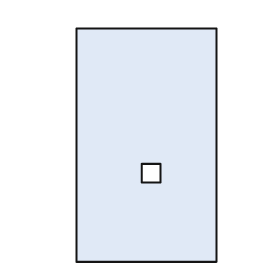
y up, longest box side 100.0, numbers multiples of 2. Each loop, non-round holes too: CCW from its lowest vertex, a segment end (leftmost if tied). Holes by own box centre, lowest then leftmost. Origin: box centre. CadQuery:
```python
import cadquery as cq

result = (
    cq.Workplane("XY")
    .moveTo(-30.0, -50.0)
    .lineTo(30.0, -50.0)
    .lineTo(30.0, 50.0)
    .lineTo(-30.0, 50.0)
    .close()
    .moveTo(-2.0, -16.0)
    .lineTo(6.0, -16.0)
    .lineTo(6.0, -8.0)
    .lineTo(-2.0, -8.0)
    .close()
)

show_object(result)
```